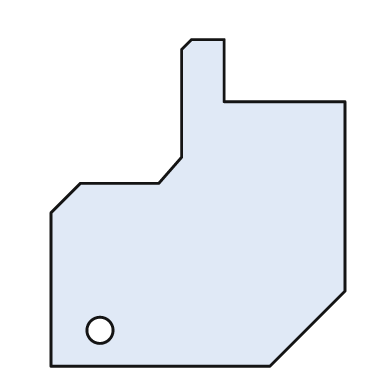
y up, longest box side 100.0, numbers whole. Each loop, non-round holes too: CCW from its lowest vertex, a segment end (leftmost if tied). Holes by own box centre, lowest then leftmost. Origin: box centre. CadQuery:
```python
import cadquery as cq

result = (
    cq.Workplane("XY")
    .moveTo(-45.0, -50.0)
    .lineTo(22.0, -50.0)
    .lineTo(45.0, -27.0)
    .lineTo(45.0, 31.0)
    .lineTo(8.0, 31.0)
    .lineTo(8.0, 50.0)
    .lineTo(-2.0, 50.0)
    .lineTo(-5.0, 47.0)
    .lineTo(-5.0, 14.0)
    .lineTo(-12.0, 6.0)
    .lineTo(-36.0, 6.0)
    .lineTo(-45.0, -3.0)
    .close()
    .moveTo(-30.0, -39.0)
    .circle(4.0)
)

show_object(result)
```